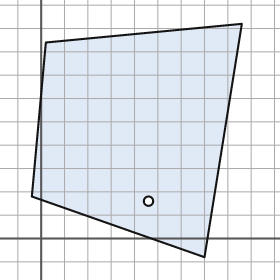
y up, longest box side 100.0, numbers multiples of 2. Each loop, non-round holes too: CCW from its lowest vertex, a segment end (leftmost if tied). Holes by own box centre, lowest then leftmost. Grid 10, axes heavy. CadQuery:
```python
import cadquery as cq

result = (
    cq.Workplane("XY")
    .moveTo(70.0, -8.0)
    .lineTo(86.0, 92.0)
    .lineTo(2.0, 84.0)
    .lineTo(-4.0, 18.0)
    .close()
    .moveTo(46.0, 16.0)
    .circle(2.0)
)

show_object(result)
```